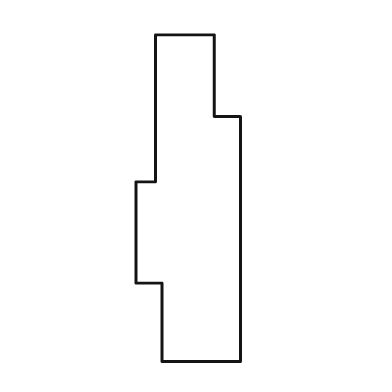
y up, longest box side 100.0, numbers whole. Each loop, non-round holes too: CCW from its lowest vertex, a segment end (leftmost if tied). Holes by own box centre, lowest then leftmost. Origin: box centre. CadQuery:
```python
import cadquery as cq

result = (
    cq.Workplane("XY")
    .moveTo(-8.0, -50.0)
    .lineTo(16.0, -50.0)
    .lineTo(16.0, 25.0)
    .lineTo(8.0, 25.0)
    .lineTo(8.0, 50.0)
    .lineTo(-10.0, 50.0)
    .lineTo(-10.0, 5.0)
    .lineTo(-16.0, 5.0)
    .lineTo(-16.0, -26.0)
    .lineTo(-8.0, -26.0)
    .close()
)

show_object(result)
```